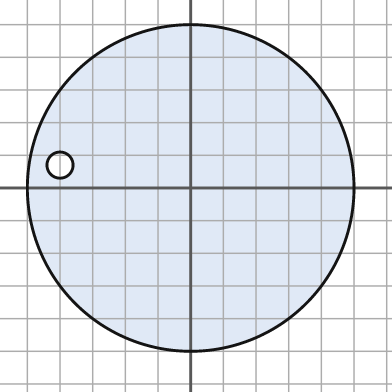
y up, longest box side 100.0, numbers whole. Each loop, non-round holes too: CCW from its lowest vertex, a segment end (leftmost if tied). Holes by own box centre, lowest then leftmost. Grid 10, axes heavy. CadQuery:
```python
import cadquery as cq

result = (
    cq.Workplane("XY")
    .moveTo(0.0, 0.0)
    .circle(50.0)
    .moveTo(-40.0, 7.0)
    .circle(4.0)
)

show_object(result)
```